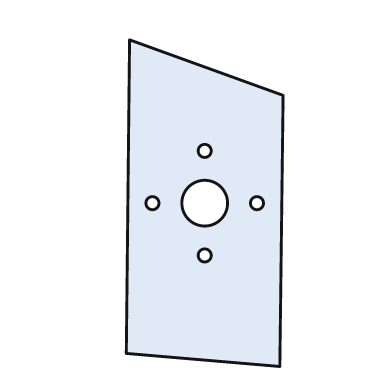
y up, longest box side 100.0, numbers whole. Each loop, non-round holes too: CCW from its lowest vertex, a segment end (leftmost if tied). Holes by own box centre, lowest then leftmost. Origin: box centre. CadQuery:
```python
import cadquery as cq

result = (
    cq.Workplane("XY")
    .moveTo(23.0, -50.0)
    .lineTo(24.0, 33.0)
    .lineTo(-23.0, 50.0)
    .lineTo(-24.0, -46.0)
    .close()
    .moveTo(0.0, -16.0)
    .circle(2.0)
    .moveTo(-16.0, 0.0)
    .circle(2.0)
    .moveTo(0.0, 0.0)
    .circle(7.0)
    .moveTo(16.0, 0.0)
    .circle(2.0)
    .moveTo(0.0, 16.0)
    .circle(2.0)
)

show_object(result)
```